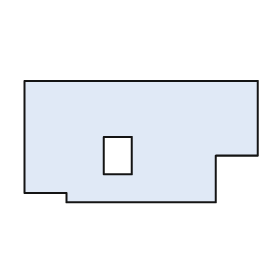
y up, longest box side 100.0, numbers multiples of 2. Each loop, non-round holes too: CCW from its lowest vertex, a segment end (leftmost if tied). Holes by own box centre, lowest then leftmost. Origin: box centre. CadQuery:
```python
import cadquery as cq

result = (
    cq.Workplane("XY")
    .moveTo(-32.0, -26.0)
    .lineTo(32.0, -26.0)
    .lineTo(32.0, -6.0)
    .lineTo(50.0, -6.0)
    .lineTo(50.0, 26.0)
    .lineTo(-50.0, 26.0)
    .lineTo(-50.0, -22.0)
    .lineTo(-32.0, -22.0)
    .close()
    .moveTo(-16.0, -14.0)
    .lineTo(-4.0, -14.0)
    .lineTo(-4.0, 2.0)
    .lineTo(-16.0, 2.0)
    .close()
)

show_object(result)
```